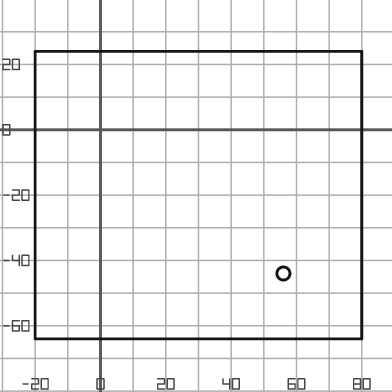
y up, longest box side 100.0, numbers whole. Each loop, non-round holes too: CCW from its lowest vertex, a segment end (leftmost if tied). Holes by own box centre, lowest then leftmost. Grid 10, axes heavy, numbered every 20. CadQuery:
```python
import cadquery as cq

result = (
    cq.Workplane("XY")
    .moveTo(-20.0, -64.0)
    .lineTo(80.0, -64.0)
    .lineTo(80.0, 24.0)
    .lineTo(-20.0, 24.0)
    .close()
    .moveTo(56.0, -44.0)
    .circle(2.0)
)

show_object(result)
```